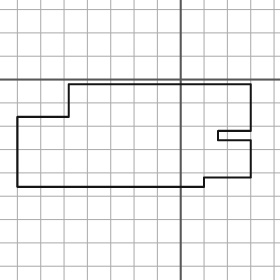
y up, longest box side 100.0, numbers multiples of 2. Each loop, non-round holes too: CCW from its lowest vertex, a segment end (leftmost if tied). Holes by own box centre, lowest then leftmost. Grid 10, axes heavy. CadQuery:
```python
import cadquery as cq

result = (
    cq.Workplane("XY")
    .moveTo(-70.0, -46.0)
    .lineTo(10.0, -46.0)
    .lineTo(10.0, -42.0)
    .lineTo(30.0, -42.0)
    .lineTo(30.0, -26.0)
    .lineTo(16.0, -26.0)
    .lineTo(16.0, -22.0)
    .lineTo(30.0, -22.0)
    .lineTo(30.0, -2.0)
    .lineTo(-48.0, -2.0)
    .lineTo(-48.0, -16.0)
    .lineTo(-70.0, -16.0)
    .close()
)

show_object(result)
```